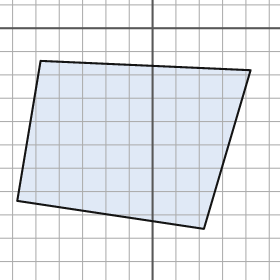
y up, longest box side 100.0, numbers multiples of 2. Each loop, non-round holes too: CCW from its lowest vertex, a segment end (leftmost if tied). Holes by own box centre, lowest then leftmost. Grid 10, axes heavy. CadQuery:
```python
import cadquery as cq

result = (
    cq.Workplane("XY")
    .moveTo(22.0, -86.0)
    .lineTo(42.0, -18.0)
    .lineTo(-48.0, -14.0)
    .lineTo(-58.0, -74.0)
    .close()
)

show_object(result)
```